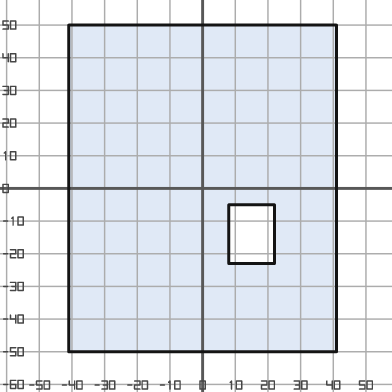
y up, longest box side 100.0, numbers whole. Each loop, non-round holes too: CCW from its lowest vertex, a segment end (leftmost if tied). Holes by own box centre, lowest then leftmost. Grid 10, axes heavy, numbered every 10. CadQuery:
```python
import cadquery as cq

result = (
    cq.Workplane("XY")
    .moveTo(-41.0, -50.0)
    .lineTo(41.0, -50.0)
    .lineTo(41.0, 50.0)
    .lineTo(-41.0, 50.0)
    .close()
    .moveTo(8.0, -23.0)
    .lineTo(22.0, -23.0)
    .lineTo(22.0, -5.0)
    .lineTo(8.0, -5.0)
    .close()
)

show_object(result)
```